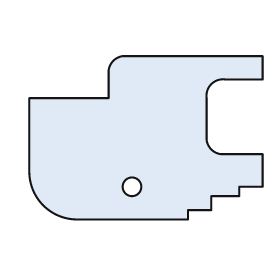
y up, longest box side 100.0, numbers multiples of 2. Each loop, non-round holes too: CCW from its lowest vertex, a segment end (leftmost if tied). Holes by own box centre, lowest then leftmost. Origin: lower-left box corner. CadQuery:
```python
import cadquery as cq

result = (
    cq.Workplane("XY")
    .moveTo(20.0, 0.0)
    .lineTo(68.0, 0.0)
    .lineTo(68.0, 4.0)
    .lineTo(78.0, 4.0)
    .lineTo(78.0, 10.0)
    .lineTo(90.0, 10.0)
    .lineTo(90.0, 14.0)
    .lineTo(100.0, 14.0)
    .lineTo(100.0, 28.0)
    .lineTo(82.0, 28.0)
    .threePointArc((78.0, 30.0), (76.0, 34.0))
    .lineTo(76.0, 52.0)
    .threePointArc((78.0, 58.0), (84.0, 60.0))
    .lineTo(100.0, 60.0)
    .lineTo(100.0, 70.0)
    .lineTo(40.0, 70.0)
    .threePointArc((36.0, 68.0), (34.0, 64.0))
    .lineTo(34.0, 52.0)
    .lineTo(0.0, 52.0)
    .lineTo(0.0, 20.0)
    .threePointArc((6.0, 6.0), (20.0, 0.0))
    .close()
    .moveTo(44.0, 14.0)
    .circle(4.0)
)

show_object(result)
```